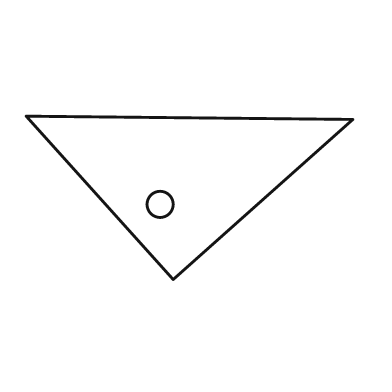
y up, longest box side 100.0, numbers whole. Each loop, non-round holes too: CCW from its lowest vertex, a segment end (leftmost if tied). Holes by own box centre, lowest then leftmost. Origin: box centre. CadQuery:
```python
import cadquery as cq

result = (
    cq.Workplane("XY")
    .moveTo(-5.0, -25.0)
    .lineTo(50.0, 24.0)
    .lineTo(-50.0, 25.0)
    .close()
    .moveTo(-9.0, -2.0)
    .circle(4.0)
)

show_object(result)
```